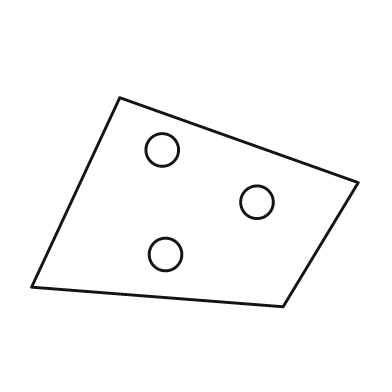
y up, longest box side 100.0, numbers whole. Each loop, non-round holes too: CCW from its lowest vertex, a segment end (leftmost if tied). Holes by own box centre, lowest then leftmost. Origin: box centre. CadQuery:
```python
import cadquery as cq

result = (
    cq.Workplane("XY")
    .moveTo(27.0, -32.0)
    .lineTo(50.0, 6.0)
    .lineTo(-23.0, 32.0)
    .lineTo(-50.0, -26.0)
    .close()
    .moveTo(-9.0, -16.0)
    .circle(5.0)
    .moveTo(19.0, 0.0)
    .circle(5.0)
    .moveTo(-10.0, 16.0)
    .circle(5.0)
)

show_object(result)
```